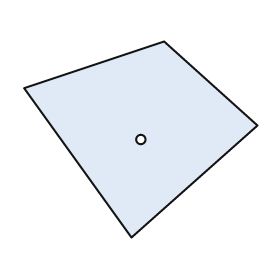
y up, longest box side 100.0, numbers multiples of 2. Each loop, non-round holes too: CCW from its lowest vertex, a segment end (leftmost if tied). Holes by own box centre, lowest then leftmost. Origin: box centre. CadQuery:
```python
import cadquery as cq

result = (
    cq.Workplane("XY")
    .moveTo(-4.0, -42.0)
    .lineTo(50.0, 6.0)
    .lineTo(10.0, 42.0)
    .lineTo(-50.0, 22.0)
    .close()
    .moveTo(0.0, 0.0)
    .circle(2.0)
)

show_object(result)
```